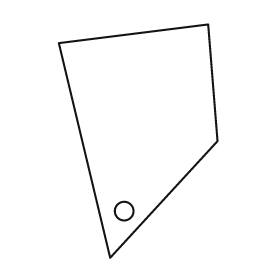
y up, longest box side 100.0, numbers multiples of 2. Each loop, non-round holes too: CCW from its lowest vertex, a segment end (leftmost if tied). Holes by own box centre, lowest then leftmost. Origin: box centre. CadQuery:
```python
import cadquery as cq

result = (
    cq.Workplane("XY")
    .moveTo(-12.0, -50.0)
    .lineTo(34.0, 0.0)
    .lineTo(30.0, 50.0)
    .lineTo(-34.0, 42.0)
    .close()
    .moveTo(-6.0, -30.0)
    .circle(4.0)
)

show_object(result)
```